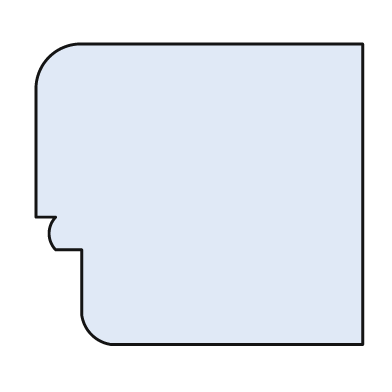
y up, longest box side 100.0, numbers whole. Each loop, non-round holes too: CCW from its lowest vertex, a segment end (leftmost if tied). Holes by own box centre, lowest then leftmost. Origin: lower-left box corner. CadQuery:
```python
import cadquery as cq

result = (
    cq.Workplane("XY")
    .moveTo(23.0, 0.0)
    .lineTo(100.0, 0.0)
    .lineTo(100.0, 92.0)
    .lineTo(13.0, 92.0)
    .threePointArc((4.0, 88.0), (0.0, 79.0))
    .lineTo(0.0, 39.0)
    .lineTo(6.0, 39.0)
    .threePointArc((4.0, 34.0), (6.0, 29.0))
    .lineTo(14.0, 29.0)
    .lineTo(14.0, 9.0)
    .threePointArc((17.0, 3.0), (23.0, 0.0))
    .close()
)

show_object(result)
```